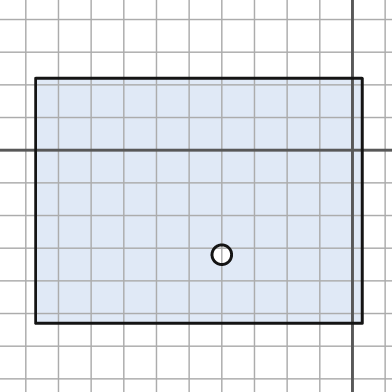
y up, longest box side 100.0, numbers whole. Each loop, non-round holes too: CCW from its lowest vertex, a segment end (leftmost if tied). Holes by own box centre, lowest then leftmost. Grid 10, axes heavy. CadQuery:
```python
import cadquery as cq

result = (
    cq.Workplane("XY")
    .moveTo(-97.0, -53.0)
    .lineTo(3.0, -53.0)
    .lineTo(3.0, 22.0)
    .lineTo(-97.0, 22.0)
    .close()
    .moveTo(-40.0, -32.0)
    .circle(3.0)
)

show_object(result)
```